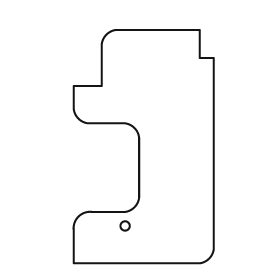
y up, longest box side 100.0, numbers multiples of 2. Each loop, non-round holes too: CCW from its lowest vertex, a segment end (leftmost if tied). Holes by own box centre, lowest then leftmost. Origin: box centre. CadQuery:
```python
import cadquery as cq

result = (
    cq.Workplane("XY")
    .moveTo(-30.0, -50.0)
    .lineTo(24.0, -50.0)
    .threePointArc((28.0, -48.0), (30.0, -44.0))
    .lineTo(30.0, 38.0)
    .lineTo(24.0, 38.0)
    .lineTo(24.0, 50.0)
    .lineTo(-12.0, 50.0)
    .threePointArc((-16.0, 48.0), (-18.0, 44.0))
    .lineTo(-18.0, 26.0)
    .lineTo(-30.0, 26.0)
    .lineTo(-30.0, 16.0)
    .threePointArc((-28.0, 12.0), (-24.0, 10.0))
    .lineTo(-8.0, 10.0)
    .threePointArc((-4.0, 8.0), (-2.0, 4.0))
    .lineTo(-2.0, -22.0)
    .threePointArc((-4.0, -26.0), (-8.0, -28.0))
    .lineTo(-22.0, -28.0)
    .threePointArc((-28.0, -30.0), (-30.0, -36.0))
    .close()
    .moveTo(-8.0, -34.0)
    .circle(2.0)
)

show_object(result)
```